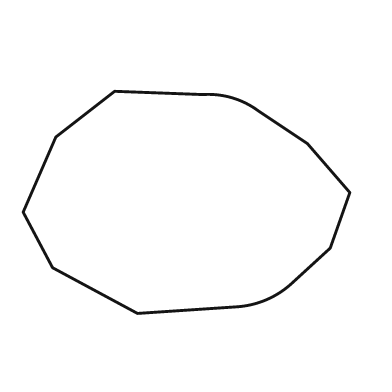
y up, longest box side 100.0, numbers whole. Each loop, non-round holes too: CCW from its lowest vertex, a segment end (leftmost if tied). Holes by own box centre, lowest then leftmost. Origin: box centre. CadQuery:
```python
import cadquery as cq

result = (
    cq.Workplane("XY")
    .moveTo(-15.0, -34.0)
    .lineTo(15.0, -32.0)
    .threePointArc((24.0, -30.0), (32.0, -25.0))
    .lineTo(44.0, -14.0)
    .lineTo(50.0, 3.0)
    .lineTo(37.0, 18.0)
    .lineTo(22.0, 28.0)
    .threePointArc((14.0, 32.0), (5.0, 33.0))
    .lineTo(-22.0, 34.0)
    .lineTo(-40.0, 20.0)
    .lineTo(-50.0, -3.0)
    .lineTo(-41.0, -20.0)
    .close()
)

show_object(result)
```